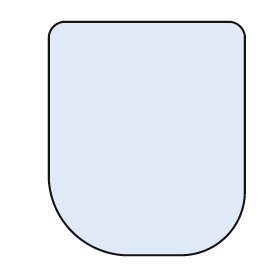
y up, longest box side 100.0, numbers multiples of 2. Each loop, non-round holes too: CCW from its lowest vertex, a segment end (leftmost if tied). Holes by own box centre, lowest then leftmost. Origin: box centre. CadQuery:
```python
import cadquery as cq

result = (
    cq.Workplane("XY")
    .moveTo(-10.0, -50.0)
    .lineTo(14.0, -50.0)
    .threePointArc((34.0, -42.0), (42.0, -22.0))
    .lineTo(42.0, 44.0)
    .threePointArc((40.0, 48.0), (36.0, 50.0))
    .lineTo(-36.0, 50.0)
    .threePointArc((-40.0, 48.0), (-42.0, 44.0))
    .lineTo(-42.0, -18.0)
    .threePointArc((-32.0, -40.0), (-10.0, -50.0))
    .close()
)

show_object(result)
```